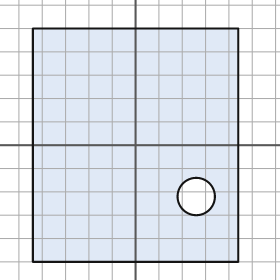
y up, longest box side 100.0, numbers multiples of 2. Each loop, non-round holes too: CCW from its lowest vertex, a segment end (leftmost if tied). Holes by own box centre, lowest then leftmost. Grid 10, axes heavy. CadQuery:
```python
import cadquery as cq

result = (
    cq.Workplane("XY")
    .moveTo(-44.0, -50.0)
    .lineTo(44.0, -50.0)
    .lineTo(44.0, 50.0)
    .lineTo(-44.0, 50.0)
    .close()
    .moveTo(26.0, -22.0)
    .circle(8.0)
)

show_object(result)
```